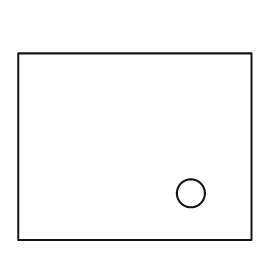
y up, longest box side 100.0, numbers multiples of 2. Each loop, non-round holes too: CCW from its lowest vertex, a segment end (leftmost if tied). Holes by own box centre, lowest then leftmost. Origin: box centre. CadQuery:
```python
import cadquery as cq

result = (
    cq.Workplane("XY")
    .moveTo(-50.0, -40.0)
    .lineTo(50.0, -40.0)
    .lineTo(50.0, 40.0)
    .lineTo(-50.0, 40.0)
    .close()
    .moveTo(24.0, -20.0)
    .circle(6.0)
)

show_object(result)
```